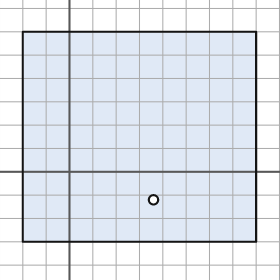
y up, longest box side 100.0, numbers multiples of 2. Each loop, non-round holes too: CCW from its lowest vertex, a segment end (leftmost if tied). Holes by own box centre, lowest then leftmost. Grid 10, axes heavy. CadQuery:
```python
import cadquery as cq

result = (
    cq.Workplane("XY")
    .moveTo(-20.0, -30.0)
    .lineTo(80.0, -30.0)
    .lineTo(80.0, 60.0)
    .lineTo(-20.0, 60.0)
    .close()
    .moveTo(36.0, -12.0)
    .circle(2.0)
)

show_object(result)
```